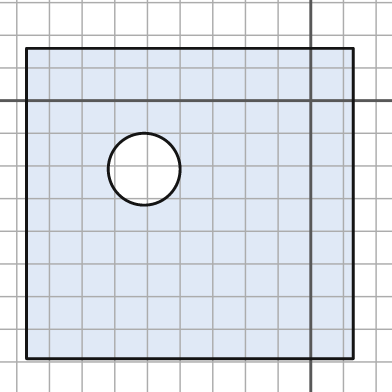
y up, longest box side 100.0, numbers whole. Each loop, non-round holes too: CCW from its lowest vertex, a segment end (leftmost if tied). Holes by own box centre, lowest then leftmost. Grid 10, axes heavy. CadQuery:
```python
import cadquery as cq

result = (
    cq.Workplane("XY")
    .moveTo(-87.0, -79.0)
    .lineTo(13.0, -79.0)
    .lineTo(13.0, 16.0)
    .lineTo(-87.0, 16.0)
    .close()
    .moveTo(-51.0, -21.0)
    .circle(11.0)
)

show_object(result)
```